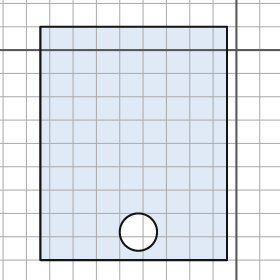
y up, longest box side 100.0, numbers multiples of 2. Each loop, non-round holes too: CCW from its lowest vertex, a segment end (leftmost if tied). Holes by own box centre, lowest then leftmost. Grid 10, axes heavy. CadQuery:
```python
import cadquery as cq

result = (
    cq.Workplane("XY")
    .moveTo(-84.0, -90.0)
    .lineTo(-4.0, -90.0)
    .lineTo(-4.0, 10.0)
    .lineTo(-84.0, 10.0)
    .close()
    .moveTo(-42.0, -78.0)
    .circle(8.0)
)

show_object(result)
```